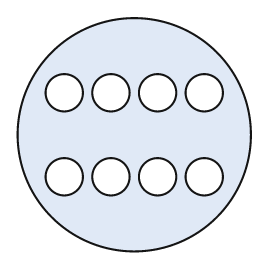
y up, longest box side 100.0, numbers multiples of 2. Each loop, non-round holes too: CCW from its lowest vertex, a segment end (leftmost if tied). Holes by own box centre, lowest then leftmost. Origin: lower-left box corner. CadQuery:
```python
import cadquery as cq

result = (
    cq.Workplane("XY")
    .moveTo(50.0, 50.0)
    .circle(50.0)
    .moveTo(20.0, 32.0)
    .circle(8.0)
    .moveTo(40.0, 32.0)
    .circle(8.0)
    .moveTo(60.0, 32.0)
    .circle(8.0)
    .moveTo(80.0, 32.0)
    .circle(8.0)
    .moveTo(20.0, 68.0)
    .circle(8.0)
    .moveTo(40.0, 68.0)
    .circle(8.0)
    .moveTo(60.0, 68.0)
    .circle(8.0)
    .moveTo(80.0, 68.0)
    .circle(8.0)
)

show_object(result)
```